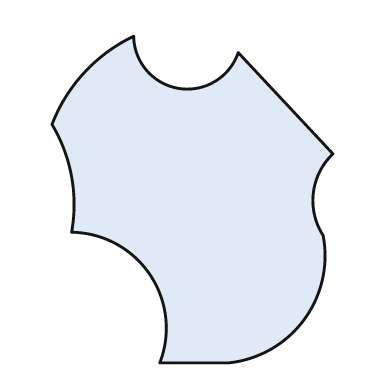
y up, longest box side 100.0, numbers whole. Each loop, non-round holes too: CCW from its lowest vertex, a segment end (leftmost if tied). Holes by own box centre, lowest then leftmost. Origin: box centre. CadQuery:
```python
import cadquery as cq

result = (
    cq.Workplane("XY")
    .moveTo(-10.0, -50.0)
    .lineTo(11.0, -50.0)
    .threePointArc((34.0, -37.0), (40.0, -11.0))
    .threePointArc((37.0, 2.0), (43.0, 14.0))
    .lineTo(14.0, 45.0)
    .threePointArc((-4.0, 34.0), (-18.0, 50.0))
    .threePointArc((-33.0, 39.0), (-43.0, 23.0))
    .threePointArc((-37.0, 7.0), (-37.0, -10.0))
    .threePointArc((-13.0, -23.0), (-10.0, -50.0))
    .close()
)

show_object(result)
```